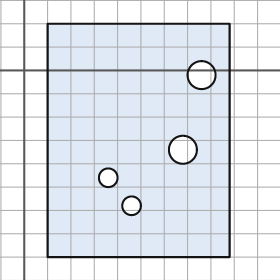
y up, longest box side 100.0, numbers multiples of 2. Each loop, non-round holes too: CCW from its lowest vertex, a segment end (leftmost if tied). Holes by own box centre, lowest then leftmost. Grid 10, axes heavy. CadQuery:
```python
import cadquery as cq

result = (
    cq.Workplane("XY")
    .moveTo(10.0, -80.0)
    .lineTo(88.0, -80.0)
    .lineTo(88.0, 20.0)
    .lineTo(10.0, 20.0)
    .close()
    .moveTo(46.0, -58.0)
    .circle(4.0)
    .moveTo(36.0, -46.0)
    .circle(4.0)
    .moveTo(68.0, -34.0)
    .circle(6.0)
    .moveTo(76.0, -2.0)
    .circle(6.0)
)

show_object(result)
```